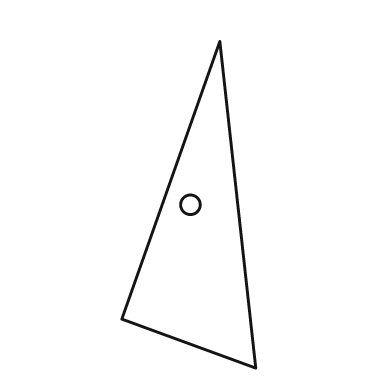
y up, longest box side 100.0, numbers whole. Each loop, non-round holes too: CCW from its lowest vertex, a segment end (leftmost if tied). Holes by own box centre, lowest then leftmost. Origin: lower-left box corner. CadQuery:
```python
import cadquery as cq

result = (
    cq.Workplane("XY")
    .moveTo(41.0, 0.0)
    .lineTo(30.0, 100.0)
    .lineTo(0.0, 15.0)
    .close()
    .moveTo(21.0, 50.0)
    .circle(3.0)
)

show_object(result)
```